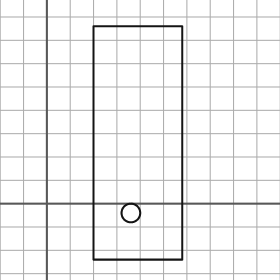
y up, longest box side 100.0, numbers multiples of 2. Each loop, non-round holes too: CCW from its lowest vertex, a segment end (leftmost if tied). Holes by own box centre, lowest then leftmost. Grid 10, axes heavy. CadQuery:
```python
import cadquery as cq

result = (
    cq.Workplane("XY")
    .moveTo(20.0, -24.0)
    .lineTo(58.0, -24.0)
    .lineTo(58.0, 76.0)
    .lineTo(20.0, 76.0)
    .close()
    .moveTo(36.0, -4.0)
    .circle(4.0)
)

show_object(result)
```